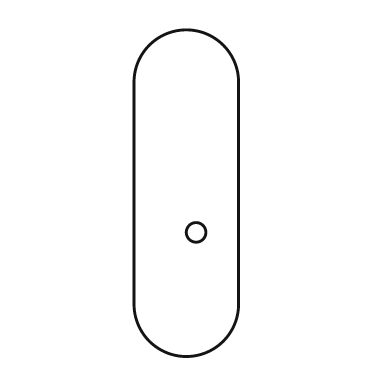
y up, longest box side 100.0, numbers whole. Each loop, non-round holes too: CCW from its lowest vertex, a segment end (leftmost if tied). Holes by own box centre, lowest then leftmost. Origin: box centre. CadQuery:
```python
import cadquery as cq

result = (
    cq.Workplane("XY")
    .moveTo(-16.0, -34.0)
    .threePointArc((0.0, -50.0), (16.0, -34.0))
    .lineTo(16.0, 34.0)
    .threePointArc((0.0, 50.0), (-16.0, 34.0))
    .close()
    .moveTo(3.0, -12.0)
    .circle(3.0)
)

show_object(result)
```